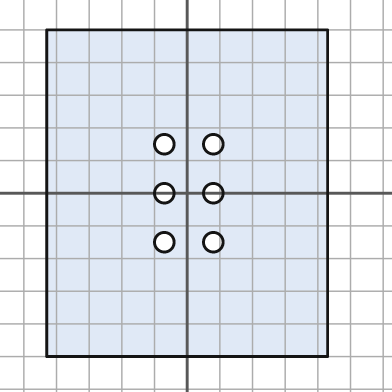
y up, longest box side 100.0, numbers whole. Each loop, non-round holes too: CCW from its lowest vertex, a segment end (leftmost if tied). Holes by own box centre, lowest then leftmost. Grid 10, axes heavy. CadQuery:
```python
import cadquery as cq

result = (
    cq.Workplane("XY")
    .moveTo(-43.0, -50.0)
    .lineTo(43.0, -50.0)
    .lineTo(43.0, 50.0)
    .lineTo(-43.0, 50.0)
    .close()
    .moveTo(-7.0, -15.0)
    .circle(3.0)
    .moveTo(8.0, -15.0)
    .circle(3.0)
    .moveTo(-7.0, 0.0)
    .circle(3.0)
    .moveTo(8.0, 0.0)
    .circle(3.0)
    .moveTo(-7.0, 15.0)
    .circle(3.0)
    .moveTo(8.0, 15.0)
    .circle(3.0)
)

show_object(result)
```